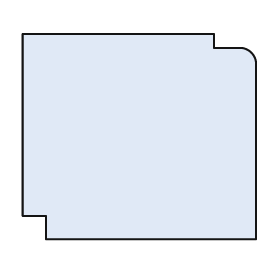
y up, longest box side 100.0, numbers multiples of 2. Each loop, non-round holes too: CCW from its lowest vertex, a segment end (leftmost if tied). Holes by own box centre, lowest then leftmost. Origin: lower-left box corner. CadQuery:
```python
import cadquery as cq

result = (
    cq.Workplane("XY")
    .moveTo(10.0, 0.0)
    .lineTo(100.0, 0.0)
    .lineTo(100.0, 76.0)
    .threePointArc((98.0, 80.0), (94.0, 82.0))
    .lineTo(82.0, 82.0)
    .lineTo(82.0, 88.0)
    .lineTo(0.0, 88.0)
    .lineTo(0.0, 10.0)
    .lineTo(10.0, 10.0)
    .close()
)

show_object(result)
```